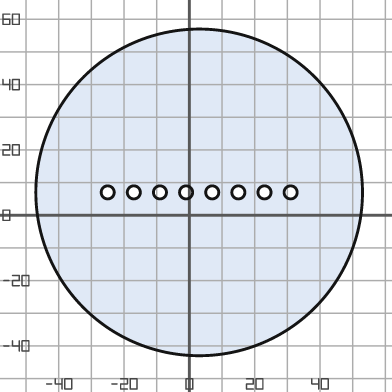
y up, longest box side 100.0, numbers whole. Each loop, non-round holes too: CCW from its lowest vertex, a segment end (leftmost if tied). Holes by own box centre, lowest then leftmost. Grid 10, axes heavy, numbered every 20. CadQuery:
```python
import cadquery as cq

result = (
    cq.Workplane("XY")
    .moveTo(3.0, 7.0)
    .circle(50.0)
    .moveTo(-25.0, 7.0)
    .circle(2.0)
    .moveTo(-17.0, 7.0)
    .circle(2.0)
    .moveTo(-9.0, 7.0)
    .circle(2.0)
    .moveTo(-1.0, 7.0)
    .circle(2.0)
    .moveTo(7.0, 7.0)
    .circle(2.0)
    .moveTo(15.0, 7.0)
    .circle(2.0)
    .moveTo(23.0, 7.0)
    .circle(2.0)
    .moveTo(31.0, 7.0)
    .circle(2.0)
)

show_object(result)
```